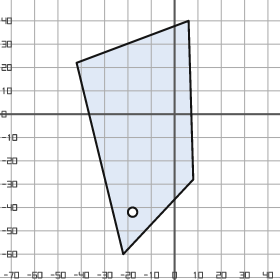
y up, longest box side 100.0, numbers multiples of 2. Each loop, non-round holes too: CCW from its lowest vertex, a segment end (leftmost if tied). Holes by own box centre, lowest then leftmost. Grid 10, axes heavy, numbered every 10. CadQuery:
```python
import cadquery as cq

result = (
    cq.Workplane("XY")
    .moveTo(-22.0, -60.0)
    .lineTo(8.0, -28.0)
    .lineTo(6.0, 40.0)
    .lineTo(-42.0, 22.0)
    .close()
    .moveTo(-18.0, -42.0)
    .circle(2.0)
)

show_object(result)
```